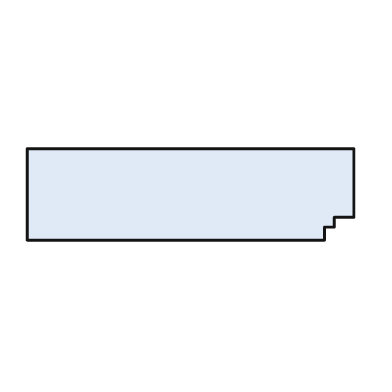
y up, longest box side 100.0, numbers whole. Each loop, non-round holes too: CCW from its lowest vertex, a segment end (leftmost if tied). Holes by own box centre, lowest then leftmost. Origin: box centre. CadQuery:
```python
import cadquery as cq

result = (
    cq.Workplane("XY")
    .moveTo(-50.0, -14.0)
    .lineTo(41.0, -14.0)
    .lineTo(41.0, -10.0)
    .lineTo(44.0, -10.0)
    .lineTo(44.0, -7.0)
    .lineTo(50.0, -7.0)
    .lineTo(50.0, 14.0)
    .lineTo(-50.0, 14.0)
    .close()
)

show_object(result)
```